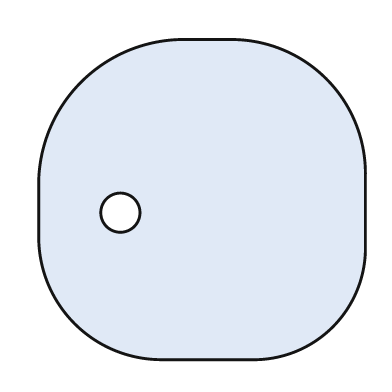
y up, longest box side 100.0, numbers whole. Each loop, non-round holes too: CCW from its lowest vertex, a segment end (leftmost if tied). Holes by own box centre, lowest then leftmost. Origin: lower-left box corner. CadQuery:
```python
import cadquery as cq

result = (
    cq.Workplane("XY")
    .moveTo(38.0, 0.0)
    .lineTo(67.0, 0.0)
    .threePointArc((90.0, 10.0), (100.0, 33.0))
    .lineTo(100.0, 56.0)
    .threePointArc((88.0, 86.0), (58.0, 98.0))
    .lineTo(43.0, 98.0)
    .threePointArc((13.0, 85.0), (0.0, 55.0))
    .lineTo(0.0, 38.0)
    .threePointArc((11.0, 11.0), (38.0, 0.0))
    .close()
    .moveTo(25.0, 45.0)
    .circle(6.0)
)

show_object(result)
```